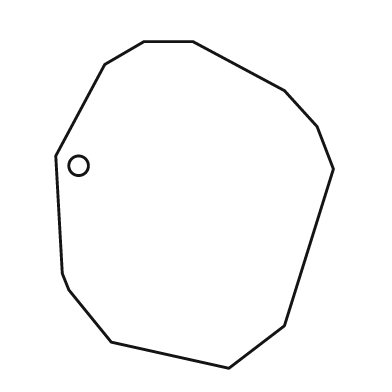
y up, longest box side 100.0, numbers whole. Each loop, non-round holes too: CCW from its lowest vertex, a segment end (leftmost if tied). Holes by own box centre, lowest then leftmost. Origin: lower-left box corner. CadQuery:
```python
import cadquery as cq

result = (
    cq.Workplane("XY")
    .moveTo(53.0, 0.0)
    .lineTo(70.0, 13.0)
    .lineTo(85.0, 61.0)
    .lineTo(80.0, 74.0)
    .lineTo(70.0, 85.0)
    .lineTo(42.0, 100.0)
    .lineTo(27.0, 100.0)
    .lineTo(15.0, 93.0)
    .lineTo(0.0, 65.0)
    .lineTo(2.0, 29.0)
    .lineTo(4.0, 24.0)
    .lineTo(17.0, 8.0)
    .close()
    .moveTo(7.0, 62.0)
    .circle(3.0)
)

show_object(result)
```